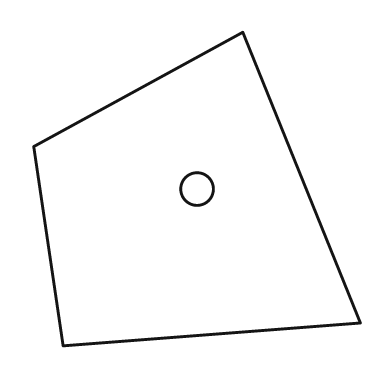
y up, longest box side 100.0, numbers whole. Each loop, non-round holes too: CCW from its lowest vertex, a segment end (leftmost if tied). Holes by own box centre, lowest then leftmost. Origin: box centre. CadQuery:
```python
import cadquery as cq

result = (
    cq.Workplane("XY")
    .moveTo(-41.0, -48.0)
    .lineTo(50.0, -41.0)
    .lineTo(14.0, 48.0)
    .lineTo(-50.0, 13.0)
    .close()
    .moveTo(0.0, 0.0)
    .circle(5.0)
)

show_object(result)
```